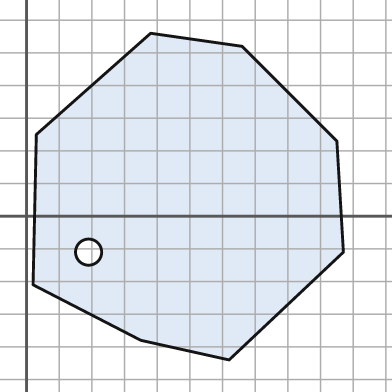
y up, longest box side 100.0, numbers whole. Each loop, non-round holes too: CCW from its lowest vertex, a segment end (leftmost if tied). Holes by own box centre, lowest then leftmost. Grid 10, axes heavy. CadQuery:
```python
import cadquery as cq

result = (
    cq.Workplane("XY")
    .moveTo(62.0, -44.0)
    .lineTo(97.0, -11.0)
    .lineTo(95.0, 23.0)
    .lineTo(66.0, 52.0)
    .lineTo(38.0, 56.0)
    .lineTo(3.0, 25.0)
    .lineTo(2.0, -21.0)
    .lineTo(35.0, -38.0)
    .close()
    .moveTo(19.0, -11.0)
    .circle(4.0)
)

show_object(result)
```